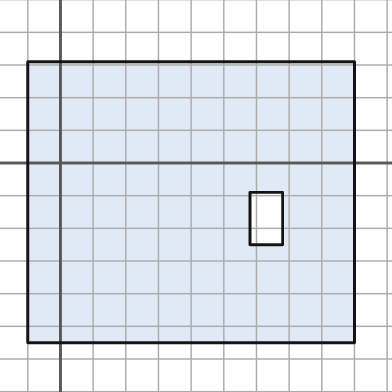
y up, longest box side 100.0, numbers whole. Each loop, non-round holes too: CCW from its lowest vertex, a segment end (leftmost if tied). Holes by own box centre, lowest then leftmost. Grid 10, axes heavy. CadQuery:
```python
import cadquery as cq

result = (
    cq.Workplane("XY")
    .moveTo(-10.0, -55.0)
    .lineTo(90.0, -55.0)
    .lineTo(90.0, 31.0)
    .lineTo(-10.0, 31.0)
    .close()
    .moveTo(58.0, -25.0)
    .lineTo(68.0, -25.0)
    .lineTo(68.0, -9.0)
    .lineTo(58.0, -9.0)
    .close()
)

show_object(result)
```